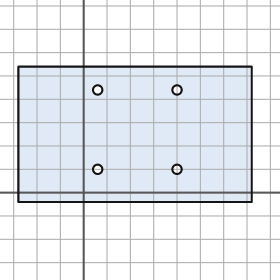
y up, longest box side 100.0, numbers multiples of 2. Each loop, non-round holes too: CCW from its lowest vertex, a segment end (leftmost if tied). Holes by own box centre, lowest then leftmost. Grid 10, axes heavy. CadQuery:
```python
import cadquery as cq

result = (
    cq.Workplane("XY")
    .moveTo(-28.0, -4.0)
    .lineTo(72.0, -4.0)
    .lineTo(72.0, 54.0)
    .lineTo(-28.0, 54.0)
    .close()
    .moveTo(6.0, 10.0)
    .circle(2.0)
    .moveTo(40.0, 10.0)
    .circle(2.0)
    .moveTo(6.0, 44.0)
    .circle(2.0)
    .moveTo(40.0, 44.0)
    .circle(2.0)
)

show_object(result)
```